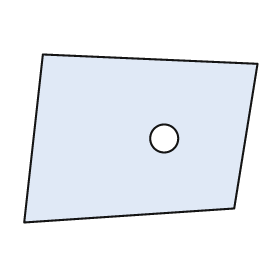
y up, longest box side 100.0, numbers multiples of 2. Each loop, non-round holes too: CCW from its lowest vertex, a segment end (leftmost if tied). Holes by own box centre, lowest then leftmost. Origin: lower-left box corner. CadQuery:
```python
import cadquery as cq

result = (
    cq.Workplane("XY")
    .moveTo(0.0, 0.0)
    .lineTo(90.0, 6.0)
    .lineTo(100.0, 68.0)
    .lineTo(8.0, 72.0)
    .close()
    .moveTo(60.0, 36.0)
    .circle(6.0)
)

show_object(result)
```